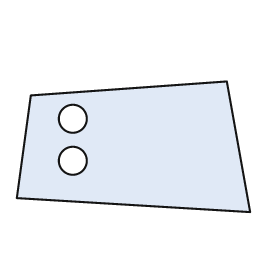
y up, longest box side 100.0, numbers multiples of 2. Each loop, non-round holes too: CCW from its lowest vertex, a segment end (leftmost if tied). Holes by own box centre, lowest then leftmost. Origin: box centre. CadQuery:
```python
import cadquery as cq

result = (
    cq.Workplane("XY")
    .moveTo(50.0, -28.0)
    .lineTo(40.0, 28.0)
    .lineTo(-44.0, 22.0)
    .lineTo(-50.0, -22.0)
    .close()
    .moveTo(-26.0, -6.0)
    .circle(6.0)
    .moveTo(-26.0, 12.0)
    .circle(6.0)
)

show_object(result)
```